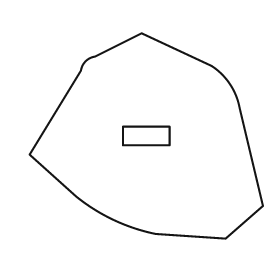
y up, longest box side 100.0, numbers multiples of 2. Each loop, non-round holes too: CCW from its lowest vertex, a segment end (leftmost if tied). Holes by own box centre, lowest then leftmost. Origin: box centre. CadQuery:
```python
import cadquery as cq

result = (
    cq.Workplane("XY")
    .moveTo(34.0, -44.0)
    .lineTo(50.0, -30.0)
    .lineTo(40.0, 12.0)
    .threePointArc((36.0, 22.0), (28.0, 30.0))
    .lineTo(-2.0, 44.0)
    .lineTo(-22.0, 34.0)
    .threePointArc((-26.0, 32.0), (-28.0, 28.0))
    .lineTo(-50.0, -8.0)
    .lineTo(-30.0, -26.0)
    .threePointArc((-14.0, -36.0), (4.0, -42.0))
    .close()
    .moveTo(-10.0, -4.0)
    .lineTo(10.0, -4.0)
    .lineTo(10.0, 4.0)
    .lineTo(-10.0, 4.0)
    .close()
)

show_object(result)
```